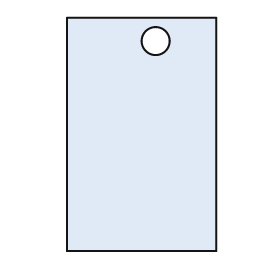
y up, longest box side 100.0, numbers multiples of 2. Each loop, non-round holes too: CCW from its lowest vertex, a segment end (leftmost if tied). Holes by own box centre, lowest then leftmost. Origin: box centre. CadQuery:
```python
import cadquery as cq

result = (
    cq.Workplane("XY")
    .moveTo(-32.0, -50.0)
    .lineTo(32.0, -50.0)
    .lineTo(32.0, 50.0)
    .lineTo(-32.0, 50.0)
    .close()
    .moveTo(6.0, 40.0)
    .circle(6.0)
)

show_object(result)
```